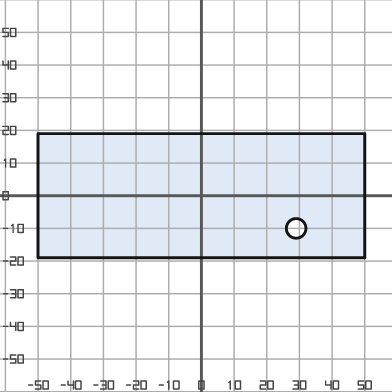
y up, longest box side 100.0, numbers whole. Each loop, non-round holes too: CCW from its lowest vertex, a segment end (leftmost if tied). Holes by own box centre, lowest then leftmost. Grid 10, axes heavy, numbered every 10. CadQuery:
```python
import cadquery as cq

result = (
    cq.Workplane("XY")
    .moveTo(-50.0, -19.0)
    .lineTo(50.0, -19.0)
    .lineTo(50.0, 19.0)
    .lineTo(-50.0, 19.0)
    .close()
    .moveTo(29.0, -10.0)
    .circle(3.0)
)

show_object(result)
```